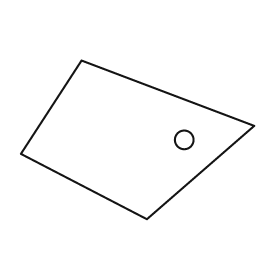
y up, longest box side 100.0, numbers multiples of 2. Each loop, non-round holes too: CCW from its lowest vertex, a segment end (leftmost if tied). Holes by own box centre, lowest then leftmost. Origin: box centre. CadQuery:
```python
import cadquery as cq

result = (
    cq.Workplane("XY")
    .moveTo(4.0, -34.0)
    .lineTo(50.0, 6.0)
    .lineTo(-24.0, 34.0)
    .lineTo(-50.0, -6.0)
    .close()
    .moveTo(20.0, 0.0)
    .circle(4.0)
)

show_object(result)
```